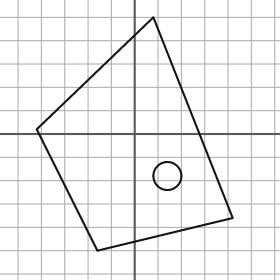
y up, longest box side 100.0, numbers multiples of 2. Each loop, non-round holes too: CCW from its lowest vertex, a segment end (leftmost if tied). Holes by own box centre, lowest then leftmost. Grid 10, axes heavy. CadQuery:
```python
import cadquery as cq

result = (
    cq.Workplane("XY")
    .moveTo(-16.0, -50.0)
    .lineTo(42.0, -36.0)
    .lineTo(8.0, 50.0)
    .lineTo(-42.0, 2.0)
    .close()
    .moveTo(14.0, -18.0)
    .circle(6.0)
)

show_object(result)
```